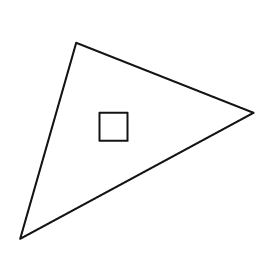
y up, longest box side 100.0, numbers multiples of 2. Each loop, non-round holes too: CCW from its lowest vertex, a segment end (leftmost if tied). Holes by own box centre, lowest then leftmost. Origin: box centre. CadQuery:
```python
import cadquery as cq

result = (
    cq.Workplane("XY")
    .moveTo(-50.0, -42.0)
    .lineTo(50.0, 12.0)
    .lineTo(-26.0, 42.0)
    .close()
    .moveTo(-16.0, 0.0)
    .lineTo(-4.0, 0.0)
    .lineTo(-4.0, 12.0)
    .lineTo(-16.0, 12.0)
    .close()
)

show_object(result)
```